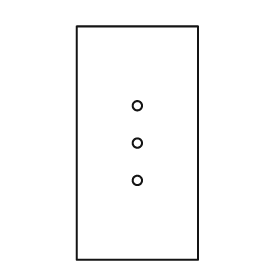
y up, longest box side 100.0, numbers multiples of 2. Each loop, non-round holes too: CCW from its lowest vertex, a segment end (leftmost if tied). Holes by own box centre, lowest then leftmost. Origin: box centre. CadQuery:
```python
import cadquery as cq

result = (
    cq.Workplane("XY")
    .moveTo(-26.0, -50.0)
    .lineTo(26.0, -50.0)
    .lineTo(26.0, 50.0)
    .lineTo(-26.0, 50.0)
    .close()
    .moveTo(0.0, -16.0)
    .circle(2.0)
    .moveTo(0.0, 0.0)
    .circle(2.0)
    .moveTo(0.0, 16.0)
    .circle(2.0)
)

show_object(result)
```